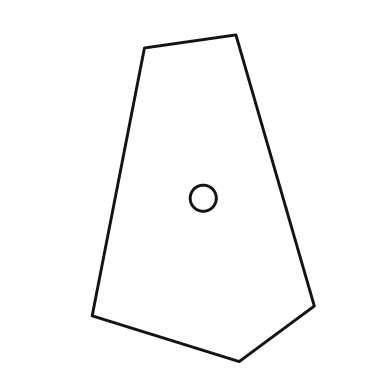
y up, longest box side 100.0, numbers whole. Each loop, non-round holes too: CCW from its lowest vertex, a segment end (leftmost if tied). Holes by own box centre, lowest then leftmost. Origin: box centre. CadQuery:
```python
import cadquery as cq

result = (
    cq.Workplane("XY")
    .moveTo(11.0, -50.0)
    .lineTo(34.0, -33.0)
    .lineTo(10.0, 50.0)
    .lineTo(-18.0, 46.0)
    .lineTo(-34.0, -36.0)
    .close()
    .moveTo(0.0, 0.0)
    .circle(4.0)
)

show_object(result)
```